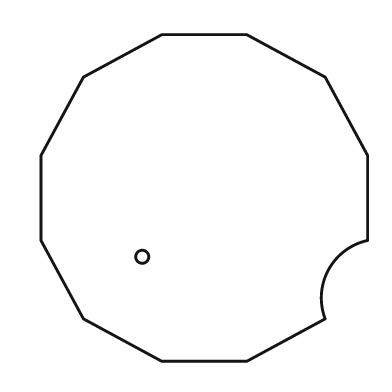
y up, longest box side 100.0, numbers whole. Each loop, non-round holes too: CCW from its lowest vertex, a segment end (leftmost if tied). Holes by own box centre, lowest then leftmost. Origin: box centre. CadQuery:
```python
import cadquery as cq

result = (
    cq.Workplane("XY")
    .moveTo(-13.0, -50.0)
    .lineTo(13.0, -50.0)
    .lineTo(37.0, -37.0)
    .threePointArc((38.0, -22.0), (50.0, -13.0))
    .lineTo(50.0, 13.0)
    .lineTo(37.0, 37.0)
    .lineTo(13.0, 50.0)
    .lineTo(-13.0, 50.0)
    .lineTo(-37.0, 37.0)
    .lineTo(-50.0, 13.0)
    .lineTo(-50.0, -13.0)
    .lineTo(-37.0, -37.0)
    .close()
    .moveTo(-19.0, -18.0)
    .circle(2.0)
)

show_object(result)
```